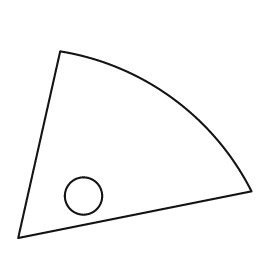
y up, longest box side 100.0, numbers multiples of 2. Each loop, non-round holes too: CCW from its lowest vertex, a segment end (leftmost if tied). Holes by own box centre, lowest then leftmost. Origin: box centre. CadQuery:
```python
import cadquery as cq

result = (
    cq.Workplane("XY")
    .moveTo(-50.0, -40.0)
    .lineTo(50.0, -20.0)
    .threePointArc((16.0, 20.0), (-32.0, 40.0))
    .close()
    .moveTo(-22.0, -22.0)
    .circle(8.0)
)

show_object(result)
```